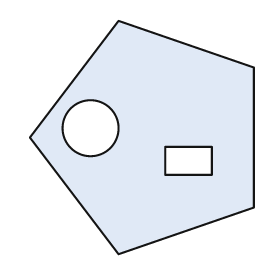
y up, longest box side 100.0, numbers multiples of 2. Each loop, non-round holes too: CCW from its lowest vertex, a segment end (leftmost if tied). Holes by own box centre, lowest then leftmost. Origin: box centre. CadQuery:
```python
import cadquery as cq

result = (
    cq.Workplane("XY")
    .moveTo(-10.0, -50.0)
    .lineTo(48.0, -30.0)
    .lineTo(48.0, 30.0)
    .lineTo(-10.0, 50.0)
    .lineTo(-48.0, 0.0)
    .close()
    .moveTo(10.0, -16.0)
    .lineTo(30.0, -16.0)
    .lineTo(30.0, -4.0)
    .lineTo(10.0, -4.0)
    .close()
    .moveTo(-22.0, 4.0)
    .circle(12.0)
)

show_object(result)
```